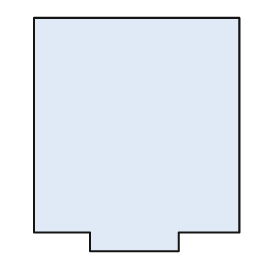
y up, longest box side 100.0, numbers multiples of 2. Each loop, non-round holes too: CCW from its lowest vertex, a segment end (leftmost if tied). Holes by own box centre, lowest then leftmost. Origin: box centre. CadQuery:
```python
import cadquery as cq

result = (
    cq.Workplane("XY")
    .moveTo(-20.0, -50.0)
    .lineTo(18.0, -50.0)
    .lineTo(18.0, -42.0)
    .lineTo(44.0, -42.0)
    .lineTo(44.0, 50.0)
    .lineTo(-44.0, 50.0)
    .lineTo(-44.0, -42.0)
    .lineTo(-20.0, -42.0)
    .close()
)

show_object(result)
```